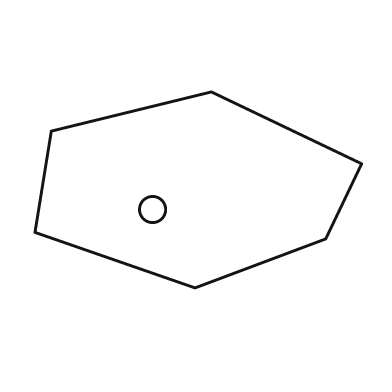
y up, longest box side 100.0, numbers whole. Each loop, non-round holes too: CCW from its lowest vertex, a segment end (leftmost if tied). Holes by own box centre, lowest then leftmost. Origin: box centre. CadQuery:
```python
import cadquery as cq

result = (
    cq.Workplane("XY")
    .moveTo(-1.0, -30.0)
    .lineTo(39.0, -15.0)
    .lineTo(50.0, 8.0)
    .lineTo(4.0, 30.0)
    .lineTo(-45.0, 18.0)
    .lineTo(-50.0, -13.0)
    .close()
    .moveTo(-14.0, -6.0)
    .circle(4.0)
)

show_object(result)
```